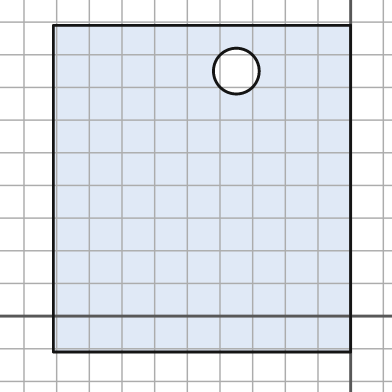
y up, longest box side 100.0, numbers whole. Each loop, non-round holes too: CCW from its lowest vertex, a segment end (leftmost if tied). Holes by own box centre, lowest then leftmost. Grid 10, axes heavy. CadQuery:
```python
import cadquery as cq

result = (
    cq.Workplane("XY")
    .moveTo(-91.0, -11.0)
    .lineTo(0.0, -11.0)
    .lineTo(0.0, 89.0)
    .lineTo(-91.0, 89.0)
    .close()
    .moveTo(-35.0, 75.0)
    .circle(7.0)
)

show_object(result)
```